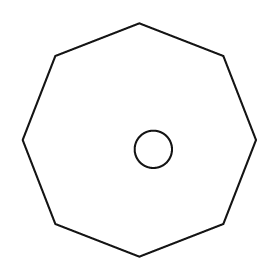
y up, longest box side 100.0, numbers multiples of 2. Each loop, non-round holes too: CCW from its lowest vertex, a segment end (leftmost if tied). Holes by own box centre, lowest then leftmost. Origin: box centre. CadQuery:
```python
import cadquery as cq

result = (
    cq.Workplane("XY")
    .moveTo(0.0, -50.0)
    .lineTo(36.0, -36.0)
    .lineTo(50.0, 0.0)
    .lineTo(36.0, 36.0)
    .lineTo(0.0, 50.0)
    .lineTo(-36.0, 36.0)
    .lineTo(-50.0, 0.0)
    .lineTo(-36.0, -36.0)
    .close()
    .moveTo(6.0, -4.0)
    .circle(8.0)
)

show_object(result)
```